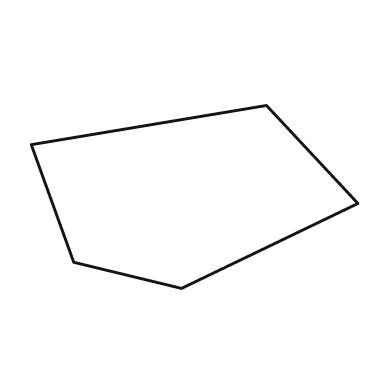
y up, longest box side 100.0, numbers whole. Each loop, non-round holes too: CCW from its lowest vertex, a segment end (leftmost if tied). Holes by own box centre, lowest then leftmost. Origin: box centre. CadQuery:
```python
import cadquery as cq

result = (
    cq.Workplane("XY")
    .moveTo(-4.0, -28.0)
    .lineTo(50.0, -2.0)
    .lineTo(22.0, 28.0)
    .lineTo(-50.0, 16.0)
    .lineTo(-37.0, -20.0)
    .close()
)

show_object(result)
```